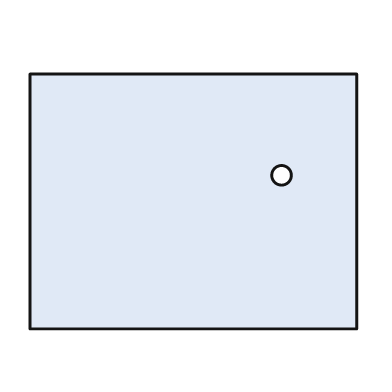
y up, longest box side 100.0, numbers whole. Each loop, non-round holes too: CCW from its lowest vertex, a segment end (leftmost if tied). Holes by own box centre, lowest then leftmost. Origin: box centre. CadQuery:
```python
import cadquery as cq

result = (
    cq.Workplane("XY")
    .moveTo(-50.0, -39.0)
    .lineTo(50.0, -39.0)
    .lineTo(50.0, 39.0)
    .lineTo(-50.0, 39.0)
    .close()
    .moveTo(27.0, 8.0)
    .circle(3.0)
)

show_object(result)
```